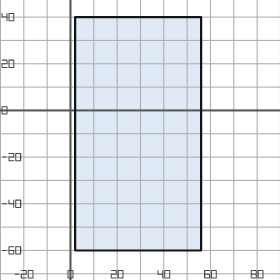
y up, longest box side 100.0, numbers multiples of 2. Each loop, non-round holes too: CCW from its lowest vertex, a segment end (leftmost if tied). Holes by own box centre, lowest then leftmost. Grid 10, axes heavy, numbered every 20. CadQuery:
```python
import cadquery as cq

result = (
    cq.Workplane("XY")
    .moveTo(2.0, -60.0)
    .lineTo(56.0, -60.0)
    .lineTo(56.0, 40.0)
    .lineTo(2.0, 40.0)
    .close()
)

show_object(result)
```